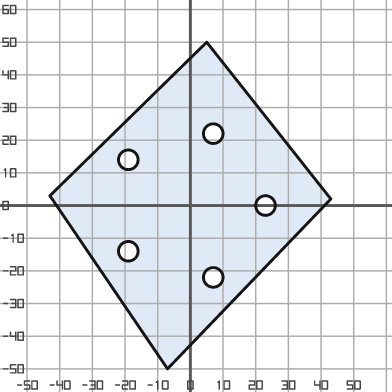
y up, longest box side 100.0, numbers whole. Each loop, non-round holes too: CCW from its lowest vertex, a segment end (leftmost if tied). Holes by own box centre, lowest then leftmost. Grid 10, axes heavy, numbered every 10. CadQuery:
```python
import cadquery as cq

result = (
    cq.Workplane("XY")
    .moveTo(-7.0, -50.0)
    .lineTo(43.0, 2.0)
    .lineTo(5.0, 50.0)
    .lineTo(-43.0, 3.0)
    .close()
    .moveTo(7.0, -22.0)
    .circle(3.0)
    .moveTo(-19.0, -14.0)
    .circle(3.0)
    .moveTo(23.0, 0.0)
    .circle(3.0)
    .moveTo(-19.0, 14.0)
    .circle(3.0)
    .moveTo(7.0, 22.0)
    .circle(3.0)
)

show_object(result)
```